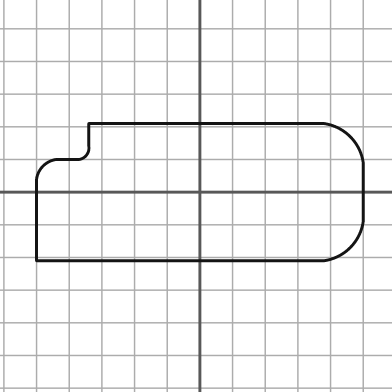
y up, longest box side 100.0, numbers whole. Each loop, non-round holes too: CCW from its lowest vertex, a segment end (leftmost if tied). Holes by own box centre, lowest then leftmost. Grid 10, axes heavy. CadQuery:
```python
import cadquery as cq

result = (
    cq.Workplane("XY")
    .moveTo(-50.0, -21.0)
    .lineTo(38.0, -21.0)
    .threePointArc((46.0, -17.0), (50.0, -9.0))
    .lineTo(50.0, 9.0)
    .threePointArc((46.0, 17.0), (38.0, 21.0))
    .lineTo(-34.0, 21.0)
    .lineTo(-34.0, 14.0)
    .threePointArc((-35.0, 11.0), (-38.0, 10.0))
    .lineTo(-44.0, 10.0)
    .threePointArc((-48.0, 8.0), (-50.0, 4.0))
    .close()
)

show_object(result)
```